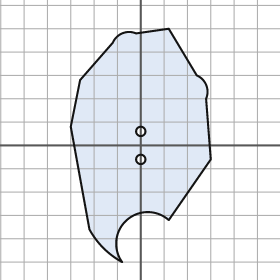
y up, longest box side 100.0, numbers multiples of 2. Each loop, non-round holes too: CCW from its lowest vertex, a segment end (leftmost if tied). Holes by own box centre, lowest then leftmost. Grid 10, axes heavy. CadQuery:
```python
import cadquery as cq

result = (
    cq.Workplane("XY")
    .moveTo(-8.0, -50.0)
    .threePointArc((-6.0, -32.0), (12.0, -32.0))
    .lineTo(30.0, -6.0)
    .lineTo(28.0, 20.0)
    .threePointArc((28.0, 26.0), (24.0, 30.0))
    .lineTo(12.0, 50.0)
    .lineTo(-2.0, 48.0)
    .threePointArc((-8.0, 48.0), (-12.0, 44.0))
    .lineTo(-26.0, 28.0)
    .lineTo(-30.0, 8.0)
    .lineTo(-22.0, -36.0)
    .threePointArc((-16.0, -44.0), (-8.0, -50.0))
    .close()
    .moveTo(0.0, -6.0)
    .circle(2.0)
    .moveTo(0.0, 6.0)
    .circle(2.0)
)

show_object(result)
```